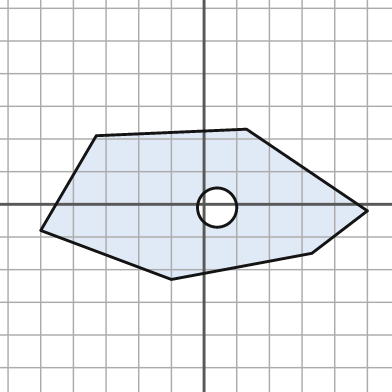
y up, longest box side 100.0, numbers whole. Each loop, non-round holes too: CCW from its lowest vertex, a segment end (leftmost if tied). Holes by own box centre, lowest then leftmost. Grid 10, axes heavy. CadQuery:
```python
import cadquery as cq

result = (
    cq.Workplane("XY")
    .moveTo(-10.0, -23.0)
    .lineTo(33.0, -15.0)
    .lineTo(50.0, -2.0)
    .lineTo(13.0, 23.0)
    .lineTo(-33.0, 21.0)
    .lineTo(-50.0, -8.0)
    .close()
    .moveTo(4.0, -1.0)
    .circle(6.0)
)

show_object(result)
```